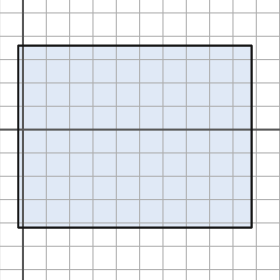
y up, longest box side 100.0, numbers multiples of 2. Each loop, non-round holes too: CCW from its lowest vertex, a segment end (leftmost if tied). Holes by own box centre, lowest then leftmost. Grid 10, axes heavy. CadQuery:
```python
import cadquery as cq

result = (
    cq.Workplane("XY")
    .moveTo(-2.0, -42.0)
    .lineTo(98.0, -42.0)
    .lineTo(98.0, 36.0)
    .lineTo(-2.0, 36.0)
    .close()
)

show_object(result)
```